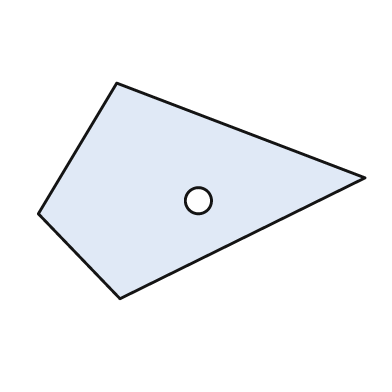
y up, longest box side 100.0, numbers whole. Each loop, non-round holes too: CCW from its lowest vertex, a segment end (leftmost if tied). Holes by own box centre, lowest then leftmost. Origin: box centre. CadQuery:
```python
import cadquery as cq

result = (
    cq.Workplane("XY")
    .moveTo(-25.0, -33.0)
    .lineTo(50.0, 4.0)
    .lineTo(-26.0, 33.0)
    .lineTo(-50.0, -7.0)
    .close()
    .moveTo(-1.0, -3.0)
    .circle(4.0)
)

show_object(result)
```